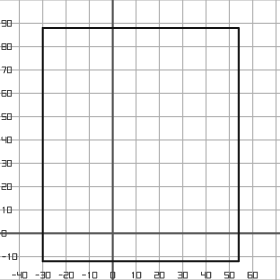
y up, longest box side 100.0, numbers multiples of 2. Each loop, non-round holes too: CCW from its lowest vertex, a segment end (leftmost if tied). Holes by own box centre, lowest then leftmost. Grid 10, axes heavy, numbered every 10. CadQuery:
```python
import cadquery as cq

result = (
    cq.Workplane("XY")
    .moveTo(-30.0, -12.0)
    .lineTo(54.0, -12.0)
    .lineTo(54.0, 88.0)
    .lineTo(-30.0, 88.0)
    .close()
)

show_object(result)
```